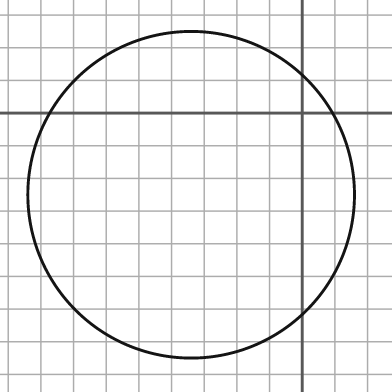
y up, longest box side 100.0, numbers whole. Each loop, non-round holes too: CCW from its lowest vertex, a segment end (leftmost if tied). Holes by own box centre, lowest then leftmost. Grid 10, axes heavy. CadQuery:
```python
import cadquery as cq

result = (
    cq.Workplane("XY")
    .moveTo(-34.0, -25.0)
    .circle(50.0)
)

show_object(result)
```